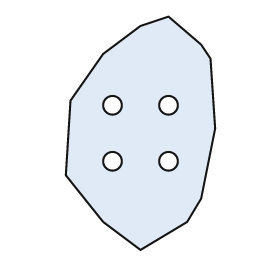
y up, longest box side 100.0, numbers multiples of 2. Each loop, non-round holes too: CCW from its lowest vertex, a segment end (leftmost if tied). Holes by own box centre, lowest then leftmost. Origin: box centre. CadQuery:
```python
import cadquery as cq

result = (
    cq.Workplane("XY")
    .moveTo(0.0, -50.0)
    .lineTo(20.0, -38.0)
    .lineTo(26.0, -28.0)
    .lineTo(32.0, 2.0)
    .lineTo(30.0, 32.0)
    .lineTo(26.0, 38.0)
    .lineTo(12.0, 50.0)
    .lineTo(0.0, 46.0)
    .lineTo(-16.0, 34.0)
    .lineTo(-30.0, 14.0)
    .lineTo(-32.0, -18.0)
    .lineTo(-16.0, -38.0)
    .close()
    .moveTo(-12.0, -12.0)
    .circle(4.0)
    .moveTo(12.0, -12.0)
    .circle(4.0)
    .moveTo(-12.0, 12.0)
    .circle(4.0)
    .moveTo(12.0, 12.0)
    .circle(4.0)
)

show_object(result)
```